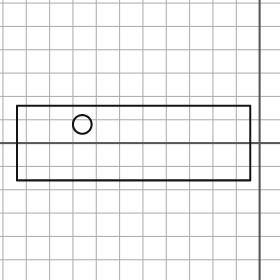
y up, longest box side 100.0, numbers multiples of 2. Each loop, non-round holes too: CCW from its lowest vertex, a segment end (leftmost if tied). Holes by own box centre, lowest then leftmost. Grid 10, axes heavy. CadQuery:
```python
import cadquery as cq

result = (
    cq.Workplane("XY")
    .moveTo(-104.0, -16.0)
    .lineTo(-4.0, -16.0)
    .lineTo(-4.0, 16.0)
    .lineTo(-104.0, 16.0)
    .close()
    .moveTo(-76.0, 8.0)
    .circle(4.0)
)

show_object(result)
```